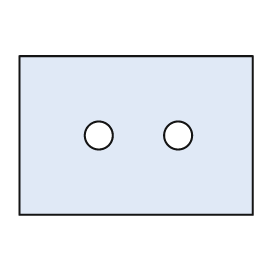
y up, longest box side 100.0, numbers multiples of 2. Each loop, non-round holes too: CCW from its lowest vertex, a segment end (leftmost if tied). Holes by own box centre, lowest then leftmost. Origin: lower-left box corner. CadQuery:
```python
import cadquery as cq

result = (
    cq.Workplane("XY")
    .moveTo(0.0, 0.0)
    .lineTo(100.0, 0.0)
    .lineTo(100.0, 68.0)
    .lineTo(0.0, 68.0)
    .close()
    .moveTo(34.0, 34.0)
    .circle(6.0)
    .moveTo(68.0, 34.0)
    .circle(6.0)
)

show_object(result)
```